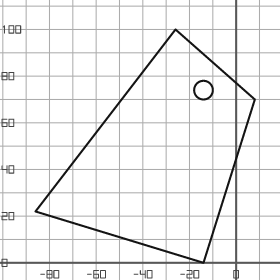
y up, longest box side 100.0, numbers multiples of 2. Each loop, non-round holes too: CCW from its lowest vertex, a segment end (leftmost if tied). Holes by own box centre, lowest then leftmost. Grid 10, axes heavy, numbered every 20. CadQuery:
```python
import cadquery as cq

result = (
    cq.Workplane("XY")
    .moveTo(-14.0, 0.0)
    .lineTo(8.0, 70.0)
    .lineTo(-26.0, 100.0)
    .lineTo(-86.0, 22.0)
    .close()
    .moveTo(-14.0, 74.0)
    .circle(4.0)
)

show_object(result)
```